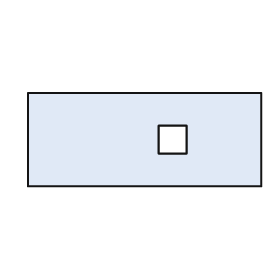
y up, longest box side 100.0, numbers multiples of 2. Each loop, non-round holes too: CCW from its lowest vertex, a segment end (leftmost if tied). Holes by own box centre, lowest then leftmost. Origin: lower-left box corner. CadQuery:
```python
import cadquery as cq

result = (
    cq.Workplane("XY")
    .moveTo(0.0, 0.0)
    .lineTo(100.0, 0.0)
    .lineTo(100.0, 40.0)
    .lineTo(0.0, 40.0)
    .close()
    .moveTo(56.0, 14.0)
    .lineTo(68.0, 14.0)
    .lineTo(68.0, 26.0)
    .lineTo(56.0, 26.0)
    .close()
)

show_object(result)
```